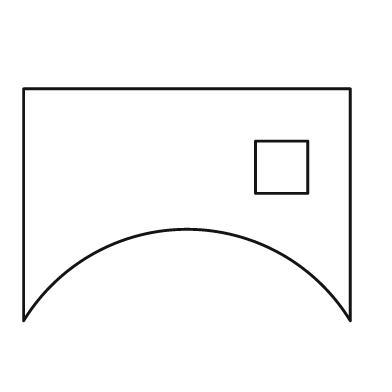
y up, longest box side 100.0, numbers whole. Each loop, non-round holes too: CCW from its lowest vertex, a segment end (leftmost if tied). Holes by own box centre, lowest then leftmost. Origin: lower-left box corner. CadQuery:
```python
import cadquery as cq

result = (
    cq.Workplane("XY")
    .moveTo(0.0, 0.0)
    .threePointArc((50.0, 28.0), (100.0, 0.0))
    .lineTo(100.0, 71.0)
    .lineTo(0.0, 71.0)
    .close()
    .moveTo(71.0, 39.0)
    .lineTo(87.0, 39.0)
    .lineTo(87.0, 55.0)
    .lineTo(71.0, 55.0)
    .close()
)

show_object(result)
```